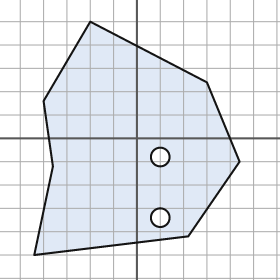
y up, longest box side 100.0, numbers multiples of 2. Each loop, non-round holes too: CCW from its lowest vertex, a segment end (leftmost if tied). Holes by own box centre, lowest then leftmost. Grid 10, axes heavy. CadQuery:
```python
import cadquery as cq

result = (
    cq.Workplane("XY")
    .moveTo(-44.0, -50.0)
    .lineTo(22.0, -42.0)
    .lineTo(44.0, -10.0)
    .lineTo(30.0, 24.0)
    .lineTo(-20.0, 50.0)
    .lineTo(-40.0, 16.0)
    .lineTo(-36.0, -12.0)
    .close()
    .moveTo(10.0, -34.0)
    .circle(4.0)
    .moveTo(10.0, -8.0)
    .circle(4.0)
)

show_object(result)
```